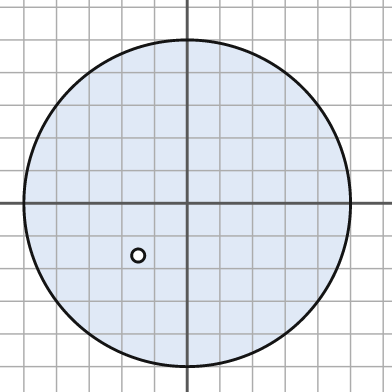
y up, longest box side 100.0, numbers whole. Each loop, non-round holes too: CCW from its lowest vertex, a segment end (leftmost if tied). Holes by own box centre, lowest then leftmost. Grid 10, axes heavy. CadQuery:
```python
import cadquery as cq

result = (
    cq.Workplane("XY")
    .moveTo(0.0, 0.0)
    .circle(50.0)
    .moveTo(-15.0, -16.0)
    .circle(2.0)
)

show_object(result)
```